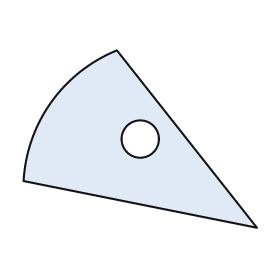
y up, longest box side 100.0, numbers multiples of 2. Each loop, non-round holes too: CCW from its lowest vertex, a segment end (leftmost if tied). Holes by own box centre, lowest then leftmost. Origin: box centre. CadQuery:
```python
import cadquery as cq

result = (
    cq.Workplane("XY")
    .moveTo(50.0, -38.0)
    .lineTo(-10.0, 38.0)
    .threePointArc((-38.0, 16.0), (-50.0, -18.0))
    .close()
    .moveTo(0.0, 0.0)
    .circle(8.0)
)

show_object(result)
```